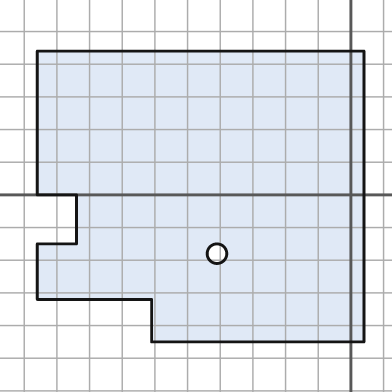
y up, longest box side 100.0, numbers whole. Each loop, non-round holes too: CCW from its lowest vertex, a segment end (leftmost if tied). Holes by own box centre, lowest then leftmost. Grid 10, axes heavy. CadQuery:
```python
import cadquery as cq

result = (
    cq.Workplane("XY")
    .moveTo(-61.0, -45.0)
    .lineTo(4.0, -45.0)
    .lineTo(4.0, 44.0)
    .lineTo(-96.0, 44.0)
    .lineTo(-96.0, 0.0)
    .lineTo(-84.0, 0.0)
    .lineTo(-84.0, -15.0)
    .lineTo(-96.0, -15.0)
    .lineTo(-96.0, -32.0)
    .lineTo(-61.0, -32.0)
    .close()
    .moveTo(-41.0, -18.0)
    .circle(3.0)
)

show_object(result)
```